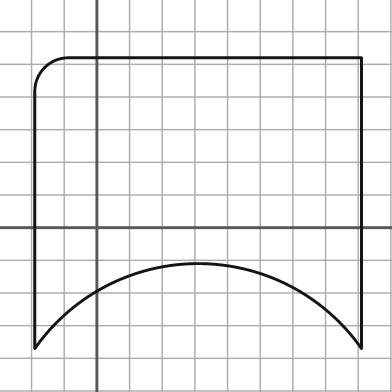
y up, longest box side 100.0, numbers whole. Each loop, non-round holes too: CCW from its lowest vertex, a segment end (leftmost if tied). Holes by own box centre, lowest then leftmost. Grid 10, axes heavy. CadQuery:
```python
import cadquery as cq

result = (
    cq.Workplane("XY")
    .moveTo(-19.0, -37.0)
    .threePointArc((31.0, -11.0), (81.0, -37.0))
    .lineTo(81.0, 52.0)
    .lineTo(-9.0, 52.0)
    .threePointArc((-16.0, 49.0), (-19.0, 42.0))
    .close()
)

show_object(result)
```